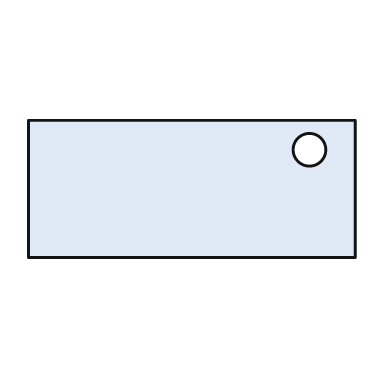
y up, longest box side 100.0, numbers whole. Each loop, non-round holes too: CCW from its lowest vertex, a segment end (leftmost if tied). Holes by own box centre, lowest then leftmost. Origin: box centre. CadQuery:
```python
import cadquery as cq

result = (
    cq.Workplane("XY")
    .moveTo(-50.0, -21.0)
    .lineTo(50.0, -21.0)
    .lineTo(50.0, 21.0)
    .lineTo(-50.0, 21.0)
    .close()
    .moveTo(36.0, 12.0)
    .circle(5.0)
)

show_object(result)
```